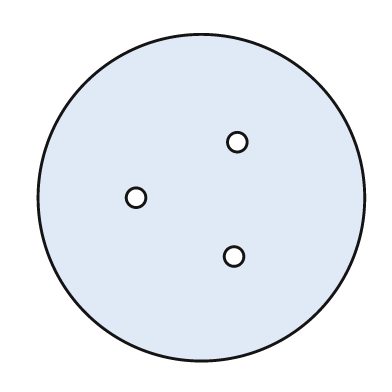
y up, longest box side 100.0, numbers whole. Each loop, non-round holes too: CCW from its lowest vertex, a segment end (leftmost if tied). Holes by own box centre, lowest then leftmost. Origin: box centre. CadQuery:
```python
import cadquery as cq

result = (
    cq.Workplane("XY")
    .moveTo(0.0, 0.0)
    .circle(50.0)
    .moveTo(10.0, -18.0)
    .circle(3.0)
    .moveTo(-20.0, 0.0)
    .circle(3.0)
    .moveTo(11.0, 17.0)
    .circle(3.0)
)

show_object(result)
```